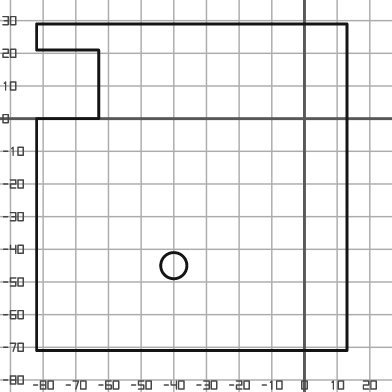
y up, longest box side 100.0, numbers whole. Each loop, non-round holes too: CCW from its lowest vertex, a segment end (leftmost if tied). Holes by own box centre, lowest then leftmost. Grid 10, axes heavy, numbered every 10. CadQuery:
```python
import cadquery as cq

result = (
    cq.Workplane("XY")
    .moveTo(-82.0, -71.0)
    .lineTo(13.0, -71.0)
    .lineTo(13.0, 29.0)
    .lineTo(-82.0, 29.0)
    .lineTo(-82.0, 21.0)
    .lineTo(-63.0, 21.0)
    .lineTo(-63.0, 0.0)
    .lineTo(-82.0, 0.0)
    .close()
    .moveTo(-40.0, -45.0)
    .circle(4.0)
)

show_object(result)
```